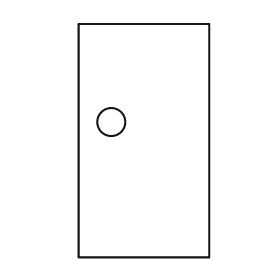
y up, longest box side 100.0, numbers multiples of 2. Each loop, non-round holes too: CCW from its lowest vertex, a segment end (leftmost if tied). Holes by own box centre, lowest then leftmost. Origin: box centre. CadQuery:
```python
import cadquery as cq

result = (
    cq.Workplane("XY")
    .moveTo(-28.0, -50.0)
    .lineTo(28.0, -50.0)
    .lineTo(28.0, 50.0)
    .lineTo(-28.0, 50.0)
    .close()
    .moveTo(-14.0, 8.0)
    .circle(6.0)
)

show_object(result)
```